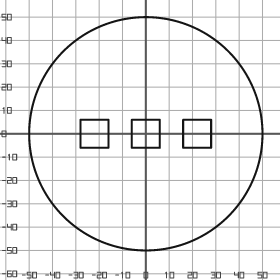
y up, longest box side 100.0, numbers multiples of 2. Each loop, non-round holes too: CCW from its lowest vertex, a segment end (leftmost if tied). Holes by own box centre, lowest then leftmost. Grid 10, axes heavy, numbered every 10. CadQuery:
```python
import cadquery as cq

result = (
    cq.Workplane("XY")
    .moveTo(0.0, 0.0)
    .circle(50.0)
    .moveTo(-28.0, -6.0)
    .lineTo(-16.0, -6.0)
    .lineTo(-16.0, 6.0)
    .lineTo(-28.0, 6.0)
    .close()
    .moveTo(-6.0, -6.0)
    .lineTo(6.0, -6.0)
    .lineTo(6.0, 6.0)
    .lineTo(-6.0, 6.0)
    .close()
    .moveTo(16.0, -6.0)
    .lineTo(28.0, -6.0)
    .lineTo(28.0, 6.0)
    .lineTo(16.0, 6.0)
    .close()
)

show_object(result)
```